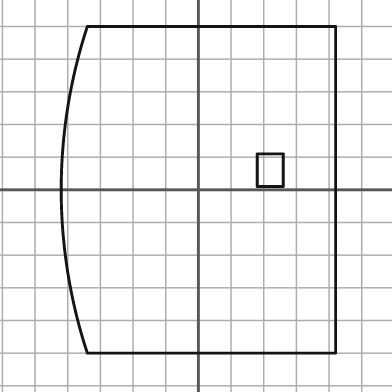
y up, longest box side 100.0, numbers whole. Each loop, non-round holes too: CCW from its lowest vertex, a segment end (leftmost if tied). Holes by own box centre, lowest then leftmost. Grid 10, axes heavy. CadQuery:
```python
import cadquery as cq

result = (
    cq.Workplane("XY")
    .moveTo(-34.0, -50.0)
    .lineTo(42.0, -50.0)
    .lineTo(42.0, 50.0)
    .lineTo(-34.0, 50.0)
    .threePointArc((-42.0, 0.0), (-34.0, -50.0))
    .close()
    .moveTo(18.0, 1.0)
    .lineTo(26.0, 1.0)
    .lineTo(26.0, 11.0)
    .lineTo(18.0, 11.0)
    .close()
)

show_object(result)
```